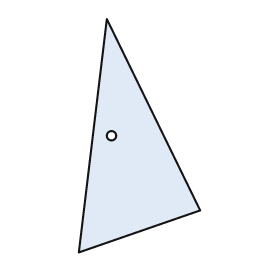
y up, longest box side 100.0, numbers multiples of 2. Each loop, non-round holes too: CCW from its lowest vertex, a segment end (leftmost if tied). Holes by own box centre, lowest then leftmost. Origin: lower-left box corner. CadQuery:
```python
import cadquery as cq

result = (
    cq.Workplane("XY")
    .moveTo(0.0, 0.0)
    .lineTo(52.0, 18.0)
    .lineTo(12.0, 100.0)
    .close()
    .moveTo(14.0, 50.0)
    .circle(2.0)
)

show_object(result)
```